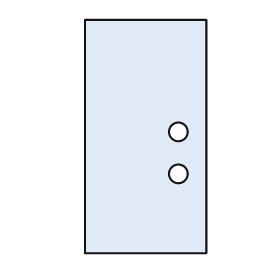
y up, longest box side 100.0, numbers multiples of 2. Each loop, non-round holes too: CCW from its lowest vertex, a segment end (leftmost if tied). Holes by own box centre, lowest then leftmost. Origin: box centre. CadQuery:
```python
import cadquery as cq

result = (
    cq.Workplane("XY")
    .moveTo(-26.0, -50.0)
    .lineTo(26.0, -50.0)
    .lineTo(26.0, 50.0)
    .lineTo(-26.0, 50.0)
    .close()
    .moveTo(14.0, -16.0)
    .circle(4.0)
    .moveTo(14.0, 2.0)
    .circle(4.0)
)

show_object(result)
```